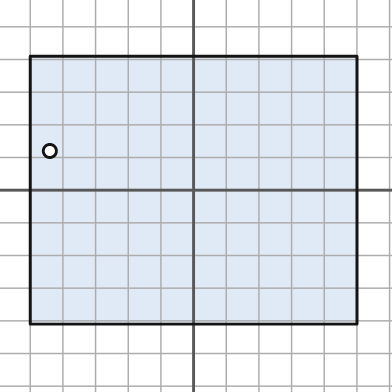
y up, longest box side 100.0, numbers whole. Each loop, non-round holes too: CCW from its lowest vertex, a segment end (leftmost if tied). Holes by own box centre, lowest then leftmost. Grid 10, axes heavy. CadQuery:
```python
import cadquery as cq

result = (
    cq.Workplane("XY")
    .moveTo(-50.0, -41.0)
    .lineTo(50.0, -41.0)
    .lineTo(50.0, 41.0)
    .lineTo(-50.0, 41.0)
    .close()
    .moveTo(-44.0, 12.0)
    .circle(2.0)
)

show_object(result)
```